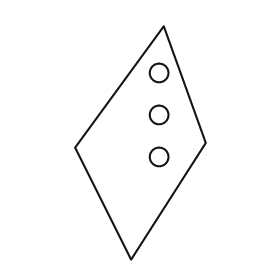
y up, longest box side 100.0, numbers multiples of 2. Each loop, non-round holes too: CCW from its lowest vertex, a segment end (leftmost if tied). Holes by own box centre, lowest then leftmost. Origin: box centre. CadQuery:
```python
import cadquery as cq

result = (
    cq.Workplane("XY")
    .moveTo(-4.0, -50.0)
    .lineTo(28.0, 0.0)
    .lineTo(10.0, 50.0)
    .lineTo(-28.0, -2.0)
    .close()
    .moveTo(8.0, -6.0)
    .circle(4.0)
    .moveTo(8.0, 12.0)
    .circle(4.0)
    .moveTo(8.0, 30.0)
    .circle(4.0)
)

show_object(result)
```